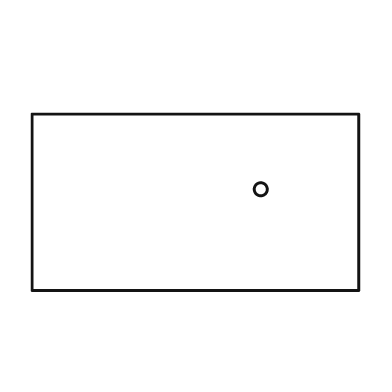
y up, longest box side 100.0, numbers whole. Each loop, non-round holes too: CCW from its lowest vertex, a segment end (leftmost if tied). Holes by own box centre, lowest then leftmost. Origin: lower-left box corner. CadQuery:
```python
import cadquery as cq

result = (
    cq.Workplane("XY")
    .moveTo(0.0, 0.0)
    .lineTo(100.0, 0.0)
    .lineTo(100.0, 54.0)
    .lineTo(0.0, 54.0)
    .close()
    .moveTo(70.0, 31.0)
    .circle(2.0)
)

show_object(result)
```